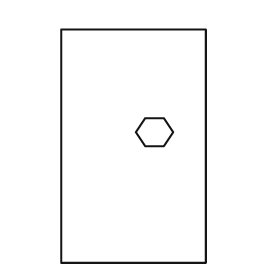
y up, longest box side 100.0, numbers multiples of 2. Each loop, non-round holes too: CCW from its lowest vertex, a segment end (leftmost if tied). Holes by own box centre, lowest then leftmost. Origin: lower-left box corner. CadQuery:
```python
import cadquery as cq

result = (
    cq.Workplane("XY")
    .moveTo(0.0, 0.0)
    .lineTo(62.0, 0.0)
    .lineTo(62.0, 100.0)
    .lineTo(0.0, 100.0)
    .close()
    .moveTo(36.0, 50.0)
    .lineTo(44.0, 50.0)
    .lineTo(48.0, 56.0)
    .lineTo(44.0, 62.0)
    .lineTo(36.0, 62.0)
    .lineTo(32.0, 56.0)
    .close()
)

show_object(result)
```